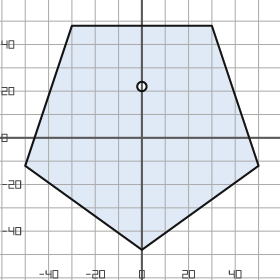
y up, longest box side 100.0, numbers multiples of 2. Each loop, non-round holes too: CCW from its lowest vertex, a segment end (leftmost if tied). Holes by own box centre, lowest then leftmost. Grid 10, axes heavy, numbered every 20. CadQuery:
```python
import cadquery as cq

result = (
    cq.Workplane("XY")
    .moveTo(0.0, -48.0)
    .lineTo(50.0, -12.0)
    .lineTo(30.0, 48.0)
    .lineTo(-30.0, 48.0)
    .lineTo(-50.0, -12.0)
    .close()
    .moveTo(0.0, 22.0)
    .circle(2.0)
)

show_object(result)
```